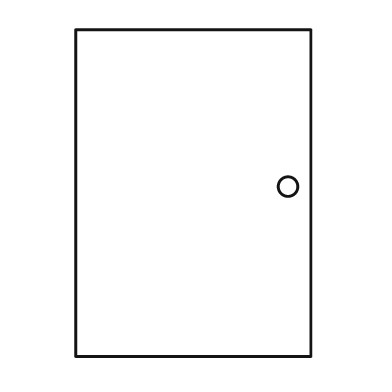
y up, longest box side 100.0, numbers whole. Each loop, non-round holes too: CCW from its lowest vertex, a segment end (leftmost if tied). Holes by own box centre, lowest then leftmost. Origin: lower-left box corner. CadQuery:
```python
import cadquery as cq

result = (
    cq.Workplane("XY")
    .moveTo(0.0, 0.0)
    .lineTo(72.0, 0.0)
    .lineTo(72.0, 100.0)
    .lineTo(0.0, 100.0)
    .close()
    .moveTo(65.0, 52.0)
    .circle(3.0)
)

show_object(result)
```